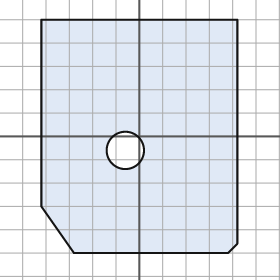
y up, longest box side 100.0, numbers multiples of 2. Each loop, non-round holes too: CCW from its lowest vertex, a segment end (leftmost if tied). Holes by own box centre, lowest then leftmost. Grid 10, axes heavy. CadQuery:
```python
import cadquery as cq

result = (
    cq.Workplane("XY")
    .moveTo(-28.0, -50.0)
    .lineTo(38.0, -50.0)
    .lineTo(42.0, -46.0)
    .lineTo(42.0, 50.0)
    .lineTo(-42.0, 50.0)
    .lineTo(-42.0, -30.0)
    .close()
    .moveTo(-6.0, -6.0)
    .circle(8.0)
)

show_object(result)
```